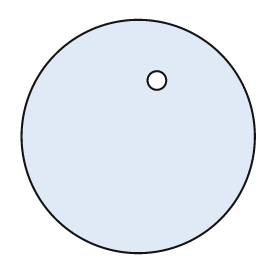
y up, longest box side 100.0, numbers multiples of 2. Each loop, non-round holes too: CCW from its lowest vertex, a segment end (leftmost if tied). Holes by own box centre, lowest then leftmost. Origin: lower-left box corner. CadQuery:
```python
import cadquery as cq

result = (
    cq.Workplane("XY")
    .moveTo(50.0, 50.0)
    .circle(50.0)
    .moveTo(58.0, 74.0)
    .circle(4.0)
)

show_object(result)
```